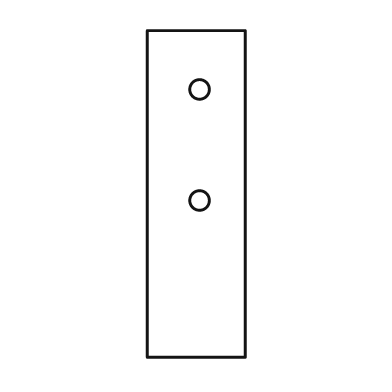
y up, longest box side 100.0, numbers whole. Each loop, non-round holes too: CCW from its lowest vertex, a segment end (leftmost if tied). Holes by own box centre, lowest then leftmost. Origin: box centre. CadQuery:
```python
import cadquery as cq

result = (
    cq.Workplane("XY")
    .moveTo(-15.0, -50.0)
    .lineTo(15.0, -50.0)
    .lineTo(15.0, 50.0)
    .lineTo(-15.0, 50.0)
    .close()
    .moveTo(1.0, -2.0)
    .circle(3.0)
    .moveTo(1.0, 32.0)
    .circle(3.0)
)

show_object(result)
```